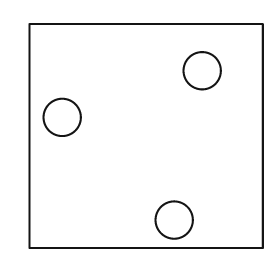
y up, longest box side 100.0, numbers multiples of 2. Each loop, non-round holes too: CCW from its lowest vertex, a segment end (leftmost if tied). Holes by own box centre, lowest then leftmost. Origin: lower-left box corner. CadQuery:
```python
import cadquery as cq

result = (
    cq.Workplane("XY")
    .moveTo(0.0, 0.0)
    .lineTo(100.0, 0.0)
    .lineTo(100.0, 96.0)
    .lineTo(0.0, 96.0)
    .close()
    .moveTo(62.0, 12.0)
    .circle(8.0)
    .moveTo(14.0, 56.0)
    .circle(8.0)
    .moveTo(74.0, 76.0)
    .circle(8.0)
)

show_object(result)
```